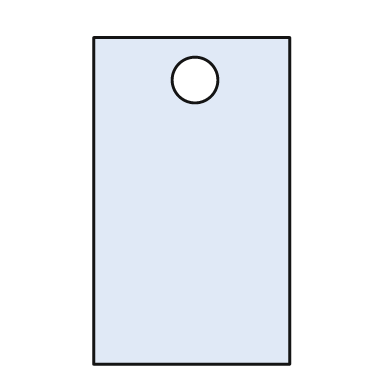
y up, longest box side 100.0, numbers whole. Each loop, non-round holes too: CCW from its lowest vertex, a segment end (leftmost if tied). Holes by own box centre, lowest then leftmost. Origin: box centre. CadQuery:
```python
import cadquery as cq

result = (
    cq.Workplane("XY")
    .moveTo(-30.0, -50.0)
    .lineTo(30.0, -50.0)
    .lineTo(30.0, 50.0)
    .lineTo(-30.0, 50.0)
    .close()
    .moveTo(1.0, 37.0)
    .circle(7.0)
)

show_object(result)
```